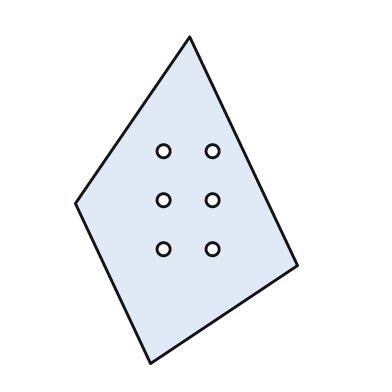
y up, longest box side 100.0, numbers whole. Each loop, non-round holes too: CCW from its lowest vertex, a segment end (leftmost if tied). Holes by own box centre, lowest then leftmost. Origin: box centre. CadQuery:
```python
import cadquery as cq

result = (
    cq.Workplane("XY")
    .moveTo(-11.0, -50.0)
    .lineTo(34.0, -20.0)
    .lineTo(1.0, 50.0)
    .lineTo(-34.0, -1.0)
    .close()
    .moveTo(-7.0, -15.0)
    .circle(2.0)
    .moveTo(8.0, -15.0)
    .circle(2.0)
    .moveTo(-7.0, 0.0)
    .circle(2.0)
    .moveTo(8.0, 0.0)
    .circle(2.0)
    .moveTo(-7.0, 15.0)
    .circle(2.0)
    .moveTo(8.0, 15.0)
    .circle(2.0)
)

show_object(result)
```